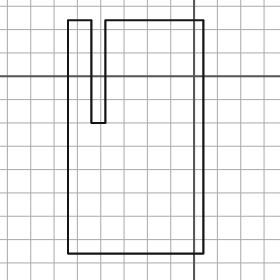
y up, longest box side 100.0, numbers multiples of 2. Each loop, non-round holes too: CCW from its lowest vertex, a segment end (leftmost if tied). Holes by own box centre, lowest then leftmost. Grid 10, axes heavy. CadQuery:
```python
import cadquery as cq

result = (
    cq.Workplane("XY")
    .moveTo(-54.0, -76.0)
    .lineTo(4.0, -76.0)
    .lineTo(4.0, 24.0)
    .lineTo(-38.0, 24.0)
    .lineTo(-38.0, -20.0)
    .lineTo(-44.0, -20.0)
    .lineTo(-44.0, 24.0)
    .lineTo(-54.0, 24.0)
    .close()
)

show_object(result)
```